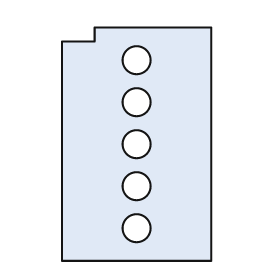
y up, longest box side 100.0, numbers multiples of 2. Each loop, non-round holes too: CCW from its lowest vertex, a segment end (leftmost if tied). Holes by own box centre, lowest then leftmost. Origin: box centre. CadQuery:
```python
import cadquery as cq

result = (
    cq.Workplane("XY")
    .moveTo(-32.0, -50.0)
    .lineTo(32.0, -50.0)
    .lineTo(32.0, 50.0)
    .lineTo(-18.0, 50.0)
    .lineTo(-18.0, 44.0)
    .lineTo(-32.0, 44.0)
    .close()
    .moveTo(0.0, -36.0)
    .circle(6.0)
    .moveTo(0.0, -18.0)
    .circle(6.0)
    .moveTo(0.0, 0.0)
    .circle(6.0)
    .moveTo(0.0, 18.0)
    .circle(6.0)
    .moveTo(0.0, 36.0)
    .circle(6.0)
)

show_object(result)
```